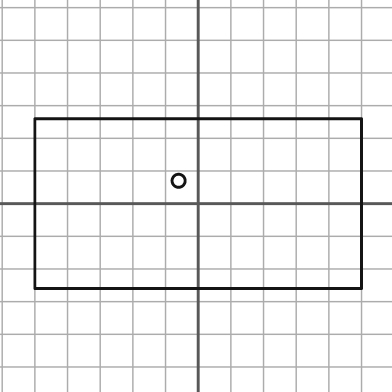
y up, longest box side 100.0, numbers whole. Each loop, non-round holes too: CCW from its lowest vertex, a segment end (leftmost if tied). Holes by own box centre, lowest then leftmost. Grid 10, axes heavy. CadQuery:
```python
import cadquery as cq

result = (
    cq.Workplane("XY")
    .moveTo(-50.0, -26.0)
    .lineTo(50.0, -26.0)
    .lineTo(50.0, 26.0)
    .lineTo(-50.0, 26.0)
    .close()
    .moveTo(-6.0, 7.0)
    .circle(2.0)
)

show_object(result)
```